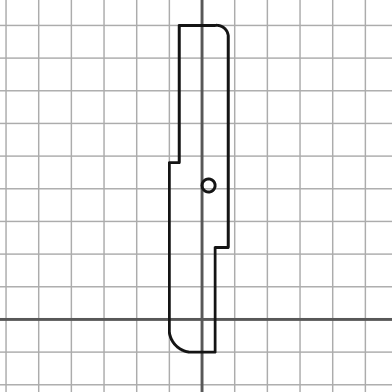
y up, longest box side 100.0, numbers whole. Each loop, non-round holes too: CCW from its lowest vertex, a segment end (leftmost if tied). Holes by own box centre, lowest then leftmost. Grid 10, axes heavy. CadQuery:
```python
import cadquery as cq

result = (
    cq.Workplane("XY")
    .moveTo(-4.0, -10.0)
    .lineTo(4.0, -10.0)
    .lineTo(4.0, 22.0)
    .lineTo(8.0, 22.0)
    .lineTo(8.0, 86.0)
    .threePointArc((7.0, 89.0), (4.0, 90.0))
    .lineTo(-7.0, 90.0)
    .lineTo(-7.0, 48.0)
    .lineTo(-10.0, 48.0)
    .lineTo(-10.0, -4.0)
    .threePointArc((-8.0, -8.0), (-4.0, -10.0))
    .close()
    .moveTo(2.0, 41.0)
    .circle(2.0)
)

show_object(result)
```